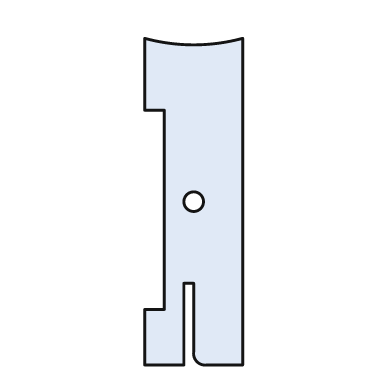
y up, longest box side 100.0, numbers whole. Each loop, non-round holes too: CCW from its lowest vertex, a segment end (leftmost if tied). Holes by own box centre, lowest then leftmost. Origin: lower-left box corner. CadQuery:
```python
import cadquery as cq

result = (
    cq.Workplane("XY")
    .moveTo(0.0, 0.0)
    .lineTo(12.0, 0.0)
    .lineTo(12.0, 25.0)
    .lineTo(15.0, 25.0)
    .lineTo(15.0, 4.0)
    .threePointArc((16.0, 1.0), (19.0, 0.0))
    .lineTo(30.0, 0.0)
    .lineTo(30.0, 100.0)
    .threePointArc((15.0, 98.0), (0.0, 100.0))
    .lineTo(0.0, 78.0)
    .lineTo(6.0, 78.0)
    .lineTo(6.0, 17.0)
    .lineTo(0.0, 17.0)
    .close()
    .moveTo(15.0, 50.0)
    .circle(3.0)
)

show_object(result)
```